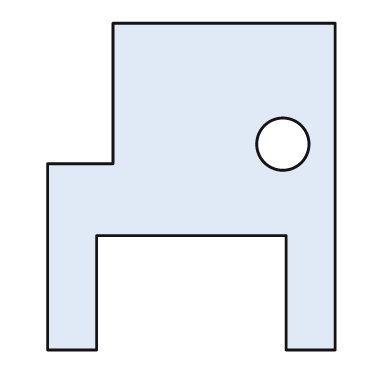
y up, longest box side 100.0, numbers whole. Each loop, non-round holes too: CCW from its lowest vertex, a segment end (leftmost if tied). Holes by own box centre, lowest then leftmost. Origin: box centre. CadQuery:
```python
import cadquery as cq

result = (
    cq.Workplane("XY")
    .moveTo(-44.0, -50.0)
    .lineTo(-29.0, -50.0)
    .lineTo(-29.0, -15.0)
    .lineTo(29.0, -15.0)
    .lineTo(29.0, -50.0)
    .lineTo(44.0, -50.0)
    .lineTo(44.0, 50.0)
    .lineTo(-24.0, 50.0)
    .lineTo(-24.0, 7.0)
    .lineTo(-44.0, 7.0)
    .close()
    .moveTo(28.0, 13.0)
    .circle(8.0)
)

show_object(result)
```